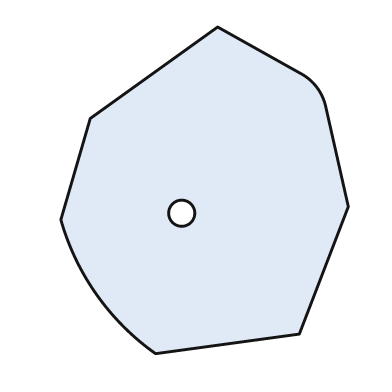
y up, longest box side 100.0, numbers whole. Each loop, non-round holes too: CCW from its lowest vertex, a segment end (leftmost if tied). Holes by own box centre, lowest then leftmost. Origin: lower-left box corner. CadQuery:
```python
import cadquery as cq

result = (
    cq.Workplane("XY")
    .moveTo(29.0, 0.0)
    .lineTo(73.0, 6.0)
    .lineTo(88.0, 45.0)
    .lineTo(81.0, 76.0)
    .threePointArc((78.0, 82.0), (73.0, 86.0))
    .lineTo(48.0, 100.0)
    .lineTo(9.0, 72.0)
    .lineTo(0.0, 41.0)
    .threePointArc((11.0, 18.0), (29.0, 0.0))
    .close()
    .moveTo(37.0, 43.0)
    .circle(4.0)
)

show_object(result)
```